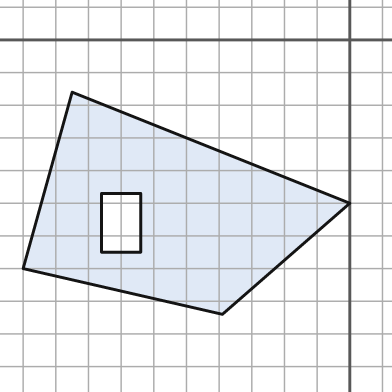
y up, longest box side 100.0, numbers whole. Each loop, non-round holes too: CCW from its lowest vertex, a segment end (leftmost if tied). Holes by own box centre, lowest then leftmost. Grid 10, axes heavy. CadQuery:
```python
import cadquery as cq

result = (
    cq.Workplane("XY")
    .moveTo(-39.0, -84.0)
    .lineTo(0.0, -50.0)
    .lineTo(-85.0, -16.0)
    .lineTo(-100.0, -70.0)
    .close()
    .moveTo(-76.0, -65.0)
    .lineTo(-64.0, -65.0)
    .lineTo(-64.0, -47.0)
    .lineTo(-76.0, -47.0)
    .close()
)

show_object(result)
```